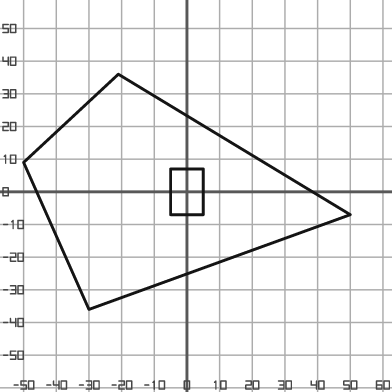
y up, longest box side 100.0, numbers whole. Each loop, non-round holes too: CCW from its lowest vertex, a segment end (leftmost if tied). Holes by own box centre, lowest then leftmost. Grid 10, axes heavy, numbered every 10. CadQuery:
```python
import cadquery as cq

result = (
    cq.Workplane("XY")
    .moveTo(-30.0, -36.0)
    .lineTo(50.0, -7.0)
    .lineTo(-21.0, 36.0)
    .lineTo(-50.0, 9.0)
    .close()
    .moveTo(-5.0, -7.0)
    .lineTo(5.0, -7.0)
    .lineTo(5.0, 7.0)
    .lineTo(-5.0, 7.0)
    .close()
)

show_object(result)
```